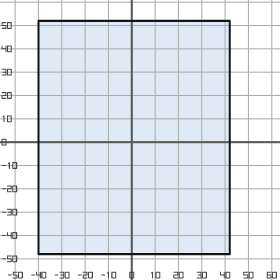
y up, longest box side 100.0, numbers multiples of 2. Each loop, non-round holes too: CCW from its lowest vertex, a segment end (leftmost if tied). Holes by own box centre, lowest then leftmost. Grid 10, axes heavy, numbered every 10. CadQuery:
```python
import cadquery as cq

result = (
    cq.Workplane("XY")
    .moveTo(-40.0, -48.0)
    .lineTo(42.0, -48.0)
    .lineTo(42.0, 52.0)
    .lineTo(-40.0, 52.0)
    .close()
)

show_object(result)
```